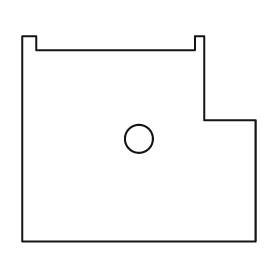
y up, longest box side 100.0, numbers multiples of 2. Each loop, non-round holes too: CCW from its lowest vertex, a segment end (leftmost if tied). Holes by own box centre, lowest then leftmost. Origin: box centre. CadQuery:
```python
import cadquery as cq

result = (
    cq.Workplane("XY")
    .moveTo(-50.0, -44.0)
    .lineTo(50.0, -44.0)
    .lineTo(50.0, 8.0)
    .lineTo(28.0, 8.0)
    .lineTo(28.0, 44.0)
    .lineTo(24.0, 44.0)
    .lineTo(24.0, 38.0)
    .lineTo(-44.0, 38.0)
    .lineTo(-44.0, 44.0)
    .lineTo(-50.0, 44.0)
    .close()
    .moveTo(0.0, 0.0)
    .circle(6.0)
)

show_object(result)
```